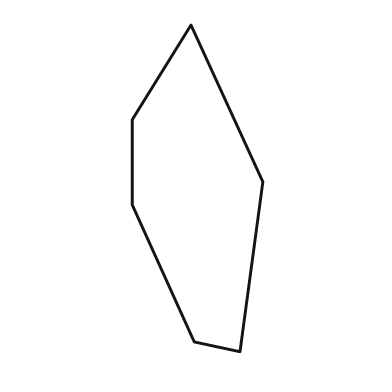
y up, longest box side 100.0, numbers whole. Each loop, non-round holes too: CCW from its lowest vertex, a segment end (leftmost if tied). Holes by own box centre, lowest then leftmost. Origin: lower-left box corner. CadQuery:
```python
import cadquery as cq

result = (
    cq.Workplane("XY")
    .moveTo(33.0, 0.0)
    .lineTo(40.0, 52.0)
    .lineTo(18.0, 100.0)
    .lineTo(0.0, 71.0)
    .lineTo(0.0, 45.0)
    .lineTo(19.0, 3.0)
    .close()
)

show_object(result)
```